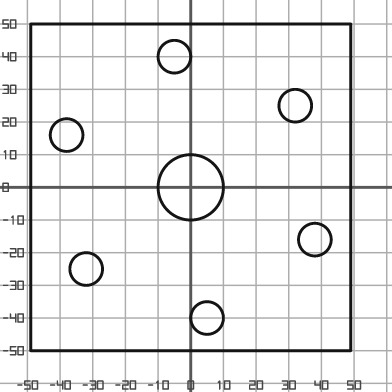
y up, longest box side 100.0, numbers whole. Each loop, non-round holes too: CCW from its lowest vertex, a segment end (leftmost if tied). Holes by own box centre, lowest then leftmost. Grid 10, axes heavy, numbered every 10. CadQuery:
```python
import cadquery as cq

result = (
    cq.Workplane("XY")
    .moveTo(-49.0, -50.0)
    .lineTo(49.0, -50.0)
    .lineTo(49.0, 50.0)
    .lineTo(-49.0, 50.0)
    .close()
    .moveTo(5.0, -40.0)
    .circle(5.0)
    .moveTo(-32.0, -25.0)
    .circle(5.0)
    .moveTo(38.0, -16.0)
    .circle(5.0)
    .moveTo(0.0, 0.0)
    .circle(10.0)
    .moveTo(-38.0, 16.0)
    .circle(5.0)
    .moveTo(32.0, 25.0)
    .circle(5.0)
    .moveTo(-5.0, 40.0)
    .circle(5.0)
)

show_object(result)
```